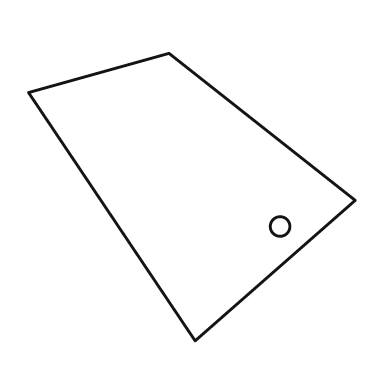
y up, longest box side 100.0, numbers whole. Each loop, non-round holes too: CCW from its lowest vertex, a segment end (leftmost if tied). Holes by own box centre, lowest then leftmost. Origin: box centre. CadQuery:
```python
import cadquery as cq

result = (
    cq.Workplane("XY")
    .moveTo(1.0, -44.0)
    .lineTo(50.0, -1.0)
    .lineTo(-7.0, 44.0)
    .lineTo(-50.0, 32.0)
    .close()
    .moveTo(27.0, -9.0)
    .circle(3.0)
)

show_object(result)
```